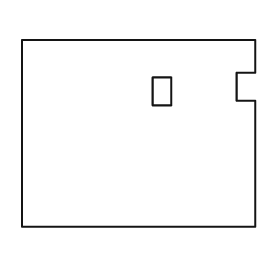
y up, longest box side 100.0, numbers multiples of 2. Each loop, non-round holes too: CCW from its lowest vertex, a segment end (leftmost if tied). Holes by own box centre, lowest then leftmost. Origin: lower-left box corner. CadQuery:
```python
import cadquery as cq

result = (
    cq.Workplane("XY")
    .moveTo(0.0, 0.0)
    .lineTo(100.0, 0.0)
    .lineTo(100.0, 54.0)
    .lineTo(92.0, 54.0)
    .lineTo(92.0, 66.0)
    .lineTo(100.0, 66.0)
    .lineTo(100.0, 80.0)
    .lineTo(0.0, 80.0)
    .close()
    .moveTo(56.0, 52.0)
    .lineTo(64.0, 52.0)
    .lineTo(64.0, 64.0)
    .lineTo(56.0, 64.0)
    .close()
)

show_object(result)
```